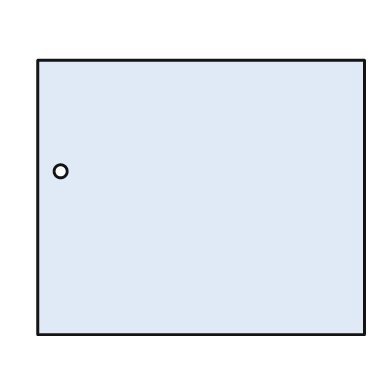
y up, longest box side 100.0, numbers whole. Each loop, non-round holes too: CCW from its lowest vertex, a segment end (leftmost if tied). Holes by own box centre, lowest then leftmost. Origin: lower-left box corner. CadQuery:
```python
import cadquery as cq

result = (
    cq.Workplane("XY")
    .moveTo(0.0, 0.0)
    .lineTo(100.0, 0.0)
    .lineTo(100.0, 84.0)
    .lineTo(0.0, 84.0)
    .close()
    .moveTo(7.0, 50.0)
    .circle(2.0)
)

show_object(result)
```